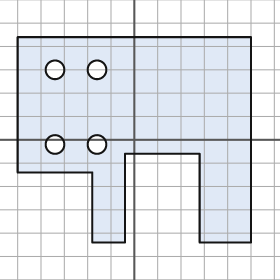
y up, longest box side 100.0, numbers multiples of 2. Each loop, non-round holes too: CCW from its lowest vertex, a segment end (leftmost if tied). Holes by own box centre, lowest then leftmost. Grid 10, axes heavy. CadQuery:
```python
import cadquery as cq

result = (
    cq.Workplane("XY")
    .moveTo(-18.0, -44.0)
    .lineTo(-4.0, -44.0)
    .lineTo(-4.0, -6.0)
    .lineTo(28.0, -6.0)
    .lineTo(28.0, -44.0)
    .lineTo(50.0, -44.0)
    .lineTo(50.0, 44.0)
    .lineTo(-50.0, 44.0)
    .lineTo(-50.0, -14.0)
    .lineTo(-18.0, -14.0)
    .close()
    .moveTo(-34.0, -2.0)
    .circle(4.0)
    .moveTo(-16.0, -2.0)
    .circle(4.0)
    .moveTo(-34.0, 30.0)
    .circle(4.0)
    .moveTo(-16.0, 30.0)
    .circle(4.0)
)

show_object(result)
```